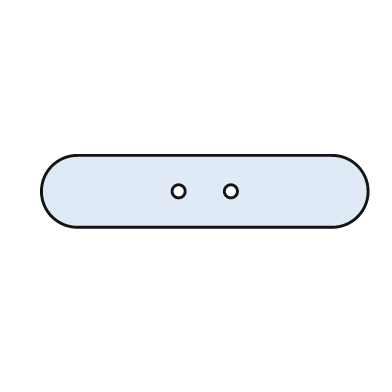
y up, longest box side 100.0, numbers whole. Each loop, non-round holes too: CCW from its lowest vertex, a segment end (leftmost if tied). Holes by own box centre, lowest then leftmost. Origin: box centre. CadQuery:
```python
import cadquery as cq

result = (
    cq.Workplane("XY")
    .moveTo(-39.0, -11.0)
    .lineTo(39.0, -11.0)
    .threePointArc((50.0, 0.0), (39.0, 11.0))
    .lineTo(-39.0, 11.0)
    .threePointArc((-50.0, 0.0), (-39.0, -11.0))
    .close()
    .moveTo(-8.0, 0.0)
    .circle(2.0)
    .moveTo(8.0, 0.0)
    .circle(2.0)
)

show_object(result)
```